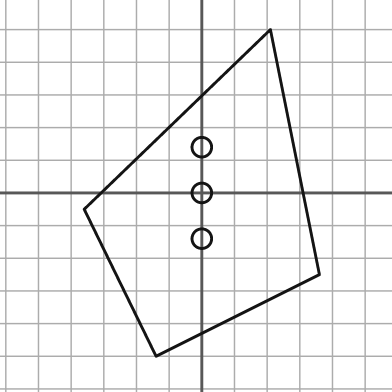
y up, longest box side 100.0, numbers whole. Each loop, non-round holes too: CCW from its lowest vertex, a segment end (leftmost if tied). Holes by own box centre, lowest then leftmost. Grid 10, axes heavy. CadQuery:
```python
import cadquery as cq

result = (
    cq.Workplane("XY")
    .moveTo(-14.0, -50.0)
    .lineTo(36.0, -25.0)
    .lineTo(21.0, 50.0)
    .lineTo(-36.0, -5.0)
    .close()
    .moveTo(0.0, -14.0)
    .circle(3.0)
    .moveTo(0.0, 0.0)
    .circle(3.0)
    .moveTo(0.0, 14.0)
    .circle(3.0)
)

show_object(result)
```